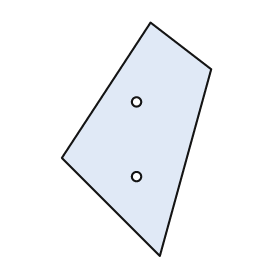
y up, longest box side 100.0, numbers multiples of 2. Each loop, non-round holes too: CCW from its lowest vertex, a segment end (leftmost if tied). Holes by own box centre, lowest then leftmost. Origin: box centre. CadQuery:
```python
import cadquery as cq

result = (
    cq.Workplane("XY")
    .moveTo(10.0, -50.0)
    .lineTo(32.0, 30.0)
    .lineTo(6.0, 50.0)
    .lineTo(-32.0, -8.0)
    .close()
    .moveTo(0.0, -16.0)
    .circle(2.0)
    .moveTo(0.0, 16.0)
    .circle(2.0)
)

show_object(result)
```